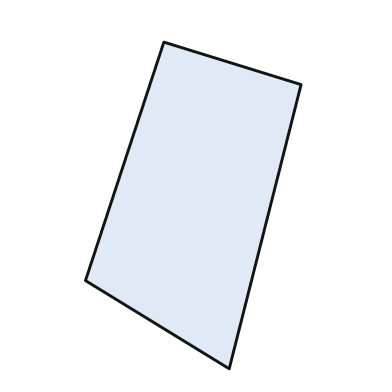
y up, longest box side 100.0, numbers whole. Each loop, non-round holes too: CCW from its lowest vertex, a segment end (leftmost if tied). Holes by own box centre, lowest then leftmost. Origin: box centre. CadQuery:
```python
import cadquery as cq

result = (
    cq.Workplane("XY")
    .moveTo(11.0, -50.0)
    .lineTo(33.0, 37.0)
    .lineTo(-9.0, 50.0)
    .lineTo(-33.0, -23.0)
    .close()
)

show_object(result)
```